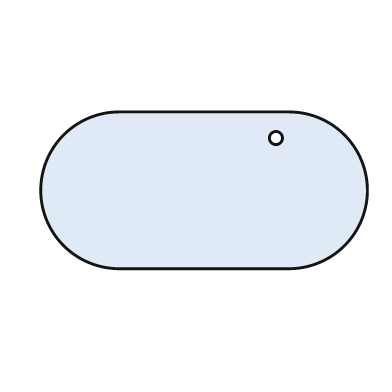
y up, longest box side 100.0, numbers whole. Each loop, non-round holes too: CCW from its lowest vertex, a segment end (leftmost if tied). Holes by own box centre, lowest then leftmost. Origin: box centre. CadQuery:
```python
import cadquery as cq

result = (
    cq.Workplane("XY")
    .moveTo(-26.0, -24.0)
    .lineTo(26.0, -24.0)
    .threePointArc((50.0, 0.0), (26.0, 24.0))
    .lineTo(-26.0, 24.0)
    .threePointArc((-50.0, 0.0), (-26.0, -24.0))
    .close()
    .moveTo(22.0, 16.0)
    .circle(2.0)
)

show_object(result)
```